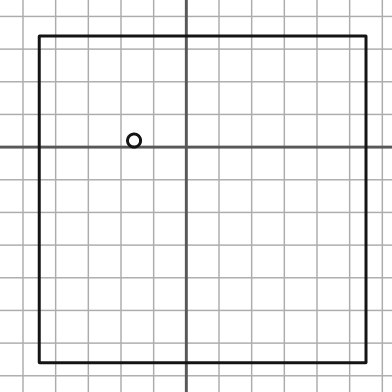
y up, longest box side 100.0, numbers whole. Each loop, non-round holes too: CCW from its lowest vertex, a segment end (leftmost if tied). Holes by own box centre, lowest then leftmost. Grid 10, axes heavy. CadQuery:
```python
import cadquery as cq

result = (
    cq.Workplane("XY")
    .moveTo(-45.0, -66.0)
    .lineTo(55.0, -66.0)
    .lineTo(55.0, 34.0)
    .lineTo(-45.0, 34.0)
    .close()
    .moveTo(-16.0, 2.0)
    .circle(2.0)
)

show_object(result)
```